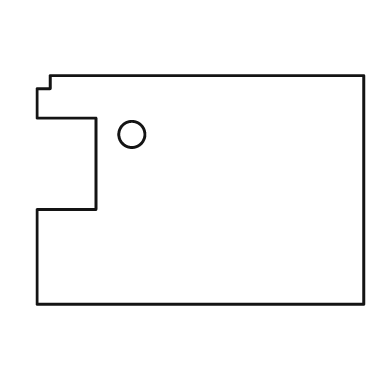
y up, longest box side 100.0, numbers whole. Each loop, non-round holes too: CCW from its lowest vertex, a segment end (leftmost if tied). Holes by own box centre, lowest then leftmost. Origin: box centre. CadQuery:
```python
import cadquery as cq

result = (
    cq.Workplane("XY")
    .moveTo(-50.0, -35.0)
    .lineTo(50.0, -35.0)
    .lineTo(50.0, 35.0)
    .lineTo(-46.0, 35.0)
    .lineTo(-46.0, 31.0)
    .lineTo(-50.0, 31.0)
    .lineTo(-50.0, 22.0)
    .lineTo(-32.0, 22.0)
    .lineTo(-32.0, -6.0)
    .lineTo(-50.0, -6.0)
    .close()
    .moveTo(-21.0, 17.0)
    .circle(4.0)
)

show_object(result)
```